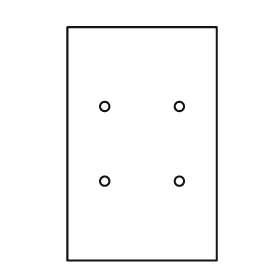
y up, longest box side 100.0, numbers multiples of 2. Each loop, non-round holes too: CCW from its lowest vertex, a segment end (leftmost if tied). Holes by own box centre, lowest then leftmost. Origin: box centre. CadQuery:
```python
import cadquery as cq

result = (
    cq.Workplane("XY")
    .moveTo(-32.0, -50.0)
    .lineTo(32.0, -50.0)
    .lineTo(32.0, 50.0)
    .lineTo(-32.0, 50.0)
    .close()
    .moveTo(-16.0, -16.0)
    .circle(2.0)
    .moveTo(16.0, -16.0)
    .circle(2.0)
    .moveTo(-16.0, 16.0)
    .circle(2.0)
    .moveTo(16.0, 16.0)
    .circle(2.0)
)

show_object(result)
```